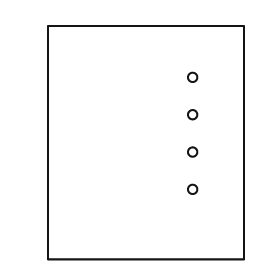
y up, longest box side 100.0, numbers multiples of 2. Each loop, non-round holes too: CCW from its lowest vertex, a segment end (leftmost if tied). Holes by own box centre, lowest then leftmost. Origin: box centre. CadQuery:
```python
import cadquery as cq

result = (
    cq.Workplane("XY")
    .moveTo(-42.0, -50.0)
    .lineTo(42.0, -50.0)
    .lineTo(42.0, 50.0)
    .lineTo(-42.0, 50.0)
    .close()
    .moveTo(20.0, -20.0)
    .circle(2.0)
    .moveTo(20.0, -4.0)
    .circle(2.0)
    .moveTo(20.0, 12.0)
    .circle(2.0)
    .moveTo(20.0, 28.0)
    .circle(2.0)
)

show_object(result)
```